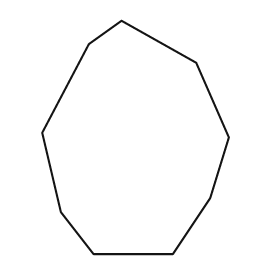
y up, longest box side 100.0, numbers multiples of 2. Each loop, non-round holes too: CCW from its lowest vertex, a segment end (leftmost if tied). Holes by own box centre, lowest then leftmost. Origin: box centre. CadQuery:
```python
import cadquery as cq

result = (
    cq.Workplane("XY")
    .moveTo(-18.0, -50.0)
    .lineTo(16.0, -50.0)
    .lineTo(32.0, -26.0)
    .lineTo(40.0, 0.0)
    .lineTo(26.0, 32.0)
    .lineTo(-6.0, 50.0)
    .lineTo(-20.0, 40.0)
    .lineTo(-40.0, 2.0)
    .lineTo(-32.0, -32.0)
    .close()
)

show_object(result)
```